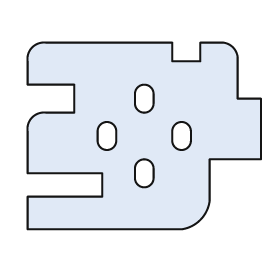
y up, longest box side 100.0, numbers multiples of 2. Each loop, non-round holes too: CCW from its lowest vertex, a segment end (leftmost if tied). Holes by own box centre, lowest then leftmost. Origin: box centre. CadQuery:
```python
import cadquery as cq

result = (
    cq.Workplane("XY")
    .moveTo(-50.0, -40.0)
    .lineTo(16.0, -40.0)
    .threePointArc((24.0, -36.0), (28.0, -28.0))
    .lineTo(28.0, -10.0)
    .lineTo(50.0, -10.0)
    .lineTo(50.0, 16.0)
    .lineTo(40.0, 16.0)
    .lineTo(40.0, 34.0)
    .threePointArc((38.0, 38.0), (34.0, 40.0))
    .lineTo(24.0, 40.0)
    .lineTo(24.0, 32.0)
    .lineTo(12.0, 32.0)
    .lineTo(12.0, 40.0)
    .lineTo(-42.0, 40.0)
    .threePointArc((-48.0, 38.0), (-50.0, 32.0))
    .lineTo(-50.0, 22.0)
    .lineTo(-30.0, 22.0)
    .lineTo(-30.0, 10.0)
    .lineTo(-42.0, 10.0)
    .threePointArc((-48.0, 8.0), (-50.0, 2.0))
    .lineTo(-50.0, -16.0)
    .lineTo(-18.0, -16.0)
    .lineTo(-18.0, -26.0)
    .lineTo(-50.0, -26.0)
    .close()
    .moveTo(-4.0, -18.0)
    .threePointArc((0.0, -22.0), (4.0, -18.0))
    .lineTo(4.0, -14.0)
    .threePointArc((0.0, -10.0), (-4.0, -14.0))
    .close()
    .moveTo(-20.0, -2.0)
    .threePointArc((-16.0, -6.0), (-12.0, -2.0))
    .lineTo(-12.0, 2.0)
    .threePointArc((-16.0, 6.0), (-20.0, 2.0))
    .close()
    .moveTo(12.0, -2.0)
    .threePointArc((16.0, -6.0), (20.0, -2.0))
    .lineTo(20.0, 2.0)
    .threePointArc((16.0, 6.0), (12.0, 2.0))
    .close()
    .moveTo(-4.0, 14.0)
    .threePointArc((0.0, 10.0), (4.0, 14.0))
    .lineTo(4.0, 18.0)
    .threePointArc((0.0, 22.0), (-4.0, 18.0))
    .close()
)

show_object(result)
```